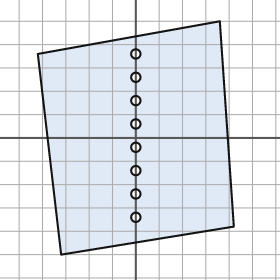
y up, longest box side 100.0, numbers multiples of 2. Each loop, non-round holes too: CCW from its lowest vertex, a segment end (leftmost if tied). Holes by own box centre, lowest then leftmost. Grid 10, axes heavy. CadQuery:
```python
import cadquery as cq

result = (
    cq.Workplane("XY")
    .moveTo(-32.0, -50.0)
    .lineTo(42.0, -38.0)
    .lineTo(36.0, 50.0)
    .lineTo(-42.0, 36.0)
    .close()
    .moveTo(0.0, -34.0)
    .circle(2.0)
    .moveTo(0.0, -24.0)
    .circle(2.0)
    .moveTo(0.0, -14.0)
    .circle(2.0)
    .moveTo(0.0, -4.0)
    .circle(2.0)
    .moveTo(0.0, 6.0)
    .circle(2.0)
    .moveTo(0.0, 16.0)
    .circle(2.0)
    .moveTo(0.0, 26.0)
    .circle(2.0)
    .moveTo(0.0, 36.0)
    .circle(2.0)
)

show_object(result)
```